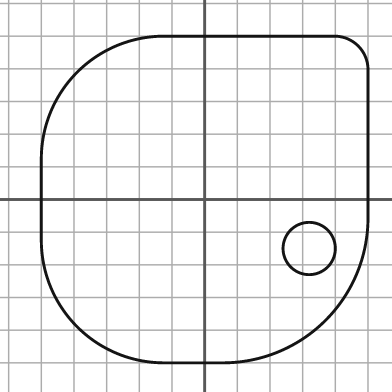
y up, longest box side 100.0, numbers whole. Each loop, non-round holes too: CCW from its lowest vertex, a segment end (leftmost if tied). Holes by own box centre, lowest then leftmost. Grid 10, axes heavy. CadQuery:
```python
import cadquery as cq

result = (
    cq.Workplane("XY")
    .moveTo(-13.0, -50.0)
    .lineTo(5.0, -50.0)
    .threePointArc((37.0, -37.0), (50.0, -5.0))
    .lineTo(50.0, 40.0)
    .threePointArc((47.0, 47.0), (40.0, 50.0))
    .lineTo(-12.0, 50.0)
    .threePointArc((-39.0, 39.0), (-50.0, 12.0))
    .lineTo(-50.0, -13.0)
    .threePointArc((-39.0, -39.0), (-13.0, -50.0))
    .close()
    .moveTo(32.0, -15.0)
    .circle(8.0)
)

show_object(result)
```